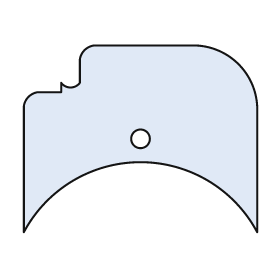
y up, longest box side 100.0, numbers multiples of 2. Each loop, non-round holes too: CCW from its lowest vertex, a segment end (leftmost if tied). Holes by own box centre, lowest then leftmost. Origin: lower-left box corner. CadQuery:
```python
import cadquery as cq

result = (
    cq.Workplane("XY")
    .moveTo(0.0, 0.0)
    .threePointArc((50.0, 30.0), (100.0, 0.0))
    .lineTo(100.0, 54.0)
    .threePointArc((92.0, 72.0), (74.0, 80.0))
    .lineTo(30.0, 80.0)
    .threePointArc((26.0, 78.0), (24.0, 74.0))
    .lineTo(24.0, 64.0)
    .threePointArc((20.0, 62.0), (16.0, 64.0))
    .lineTo(16.0, 60.0)
    .lineTo(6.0, 60.0)
    .threePointArc((2.0, 58.0), (0.0, 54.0))
    .close()
    .moveTo(50.0, 40.0)
    .circle(4.0)
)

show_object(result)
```